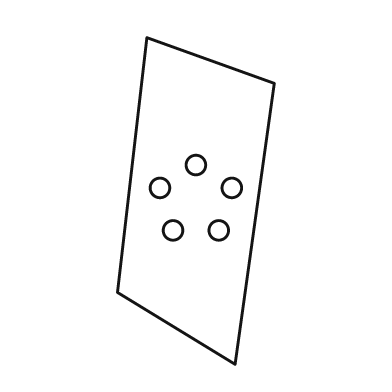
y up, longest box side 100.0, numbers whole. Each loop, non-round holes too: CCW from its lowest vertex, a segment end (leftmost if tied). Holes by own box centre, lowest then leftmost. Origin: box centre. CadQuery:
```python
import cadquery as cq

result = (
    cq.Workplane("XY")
    .moveTo(12.0, -50.0)
    .lineTo(24.0, 36.0)
    .lineTo(-15.0, 50.0)
    .lineTo(-24.0, -28.0)
    .close()
    .moveTo(-7.0, -9.0)
    .circle(3.0)
    .moveTo(7.0, -9.0)
    .circle(3.0)
    .moveTo(-11.0, 4.0)
    .circle(3.0)
    .moveTo(11.0, 4.0)
    .circle(3.0)
    .moveTo(0.0, 11.0)
    .circle(3.0)
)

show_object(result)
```